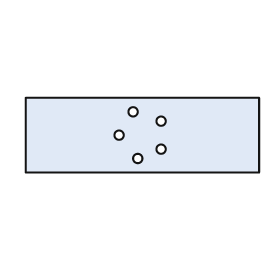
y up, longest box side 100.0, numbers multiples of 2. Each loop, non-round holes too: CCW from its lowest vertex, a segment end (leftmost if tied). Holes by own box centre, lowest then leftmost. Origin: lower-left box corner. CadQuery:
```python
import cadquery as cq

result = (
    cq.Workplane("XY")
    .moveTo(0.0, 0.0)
    .lineTo(100.0, 0.0)
    .lineTo(100.0, 32.0)
    .lineTo(0.0, 32.0)
    .close()
    .moveTo(48.0, 6.0)
    .circle(2.0)
    .moveTo(58.0, 10.0)
    .circle(2.0)
    .moveTo(40.0, 16.0)
    .circle(2.0)
    .moveTo(58.0, 22.0)
    .circle(2.0)
    .moveTo(46.0, 26.0)
    .circle(2.0)
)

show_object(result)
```